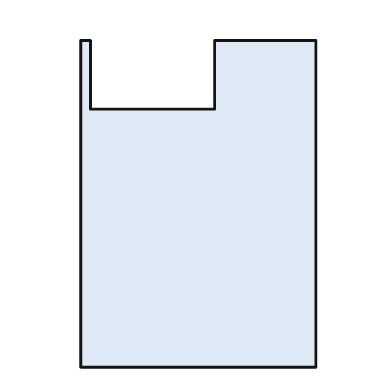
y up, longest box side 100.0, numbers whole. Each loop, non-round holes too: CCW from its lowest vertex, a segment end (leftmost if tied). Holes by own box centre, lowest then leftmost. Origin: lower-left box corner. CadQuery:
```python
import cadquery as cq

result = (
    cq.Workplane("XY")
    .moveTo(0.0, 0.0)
    .lineTo(72.0, 0.0)
    .lineTo(72.0, 100.0)
    .lineTo(41.0, 100.0)
    .lineTo(41.0, 79.0)
    .lineTo(3.0, 79.0)
    .lineTo(3.0, 100.0)
    .lineTo(0.0, 100.0)
    .close()
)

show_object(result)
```